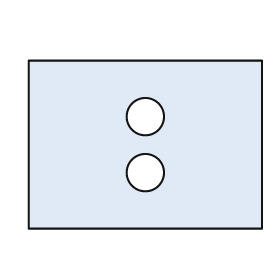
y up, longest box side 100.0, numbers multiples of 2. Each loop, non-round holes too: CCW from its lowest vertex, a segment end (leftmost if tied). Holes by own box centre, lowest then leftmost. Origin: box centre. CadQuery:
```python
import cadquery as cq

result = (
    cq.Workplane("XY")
    .moveTo(-50.0, -36.0)
    .lineTo(50.0, -36.0)
    .lineTo(50.0, 36.0)
    .lineTo(-50.0, 36.0)
    .close()
    .moveTo(0.0, -12.0)
    .circle(8.0)
    .moveTo(0.0, 12.0)
    .circle(8.0)
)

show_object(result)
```